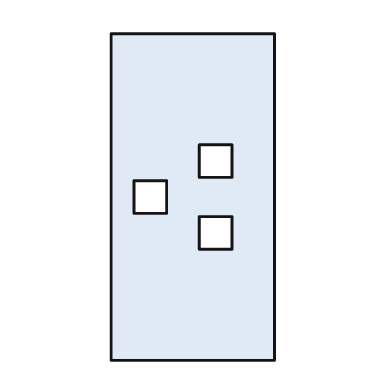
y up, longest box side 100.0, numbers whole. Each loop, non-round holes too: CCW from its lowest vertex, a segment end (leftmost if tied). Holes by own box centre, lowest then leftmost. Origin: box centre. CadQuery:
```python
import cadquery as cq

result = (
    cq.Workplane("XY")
    .moveTo(-25.0, -50.0)
    .lineTo(25.0, -50.0)
    .lineTo(25.0, 50.0)
    .lineTo(-25.0, 50.0)
    .close()
    .moveTo(2.0, -16.0)
    .lineTo(12.0, -16.0)
    .lineTo(12.0, -6.0)
    .lineTo(2.0, -6.0)
    .close()
    .moveTo(-18.0, -5.0)
    .lineTo(-8.0, -5.0)
    .lineTo(-8.0, 5.0)
    .lineTo(-18.0, 5.0)
    .close()
    .moveTo(2.0, 6.0)
    .lineTo(12.0, 6.0)
    .lineTo(12.0, 16.0)
    .lineTo(2.0, 16.0)
    .close()
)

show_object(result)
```